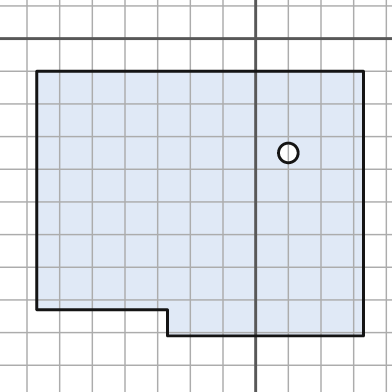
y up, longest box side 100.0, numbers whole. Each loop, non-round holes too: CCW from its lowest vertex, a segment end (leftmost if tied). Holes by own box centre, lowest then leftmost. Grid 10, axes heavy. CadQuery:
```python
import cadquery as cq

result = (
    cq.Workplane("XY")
    .moveTo(-27.0, -91.0)
    .lineTo(33.0, -91.0)
    .lineTo(33.0, -10.0)
    .lineTo(-67.0, -10.0)
    .lineTo(-67.0, -83.0)
    .lineTo(-27.0, -83.0)
    .close()
    .moveTo(10.0, -35.0)
    .circle(3.0)
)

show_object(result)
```